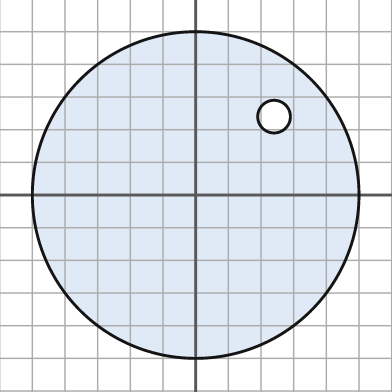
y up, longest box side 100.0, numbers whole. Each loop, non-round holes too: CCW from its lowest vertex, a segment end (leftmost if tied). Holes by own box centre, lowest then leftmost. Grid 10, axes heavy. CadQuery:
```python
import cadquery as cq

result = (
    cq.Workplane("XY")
    .moveTo(0.0, 0.0)
    .circle(50.0)
    .moveTo(24.0, 24.0)
    .circle(5.0)
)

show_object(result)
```